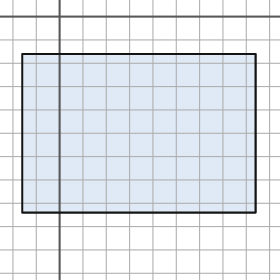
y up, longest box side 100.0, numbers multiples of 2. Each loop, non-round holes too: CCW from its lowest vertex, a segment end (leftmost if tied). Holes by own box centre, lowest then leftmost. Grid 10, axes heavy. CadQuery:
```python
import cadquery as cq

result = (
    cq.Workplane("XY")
    .moveTo(-16.0, -84.0)
    .lineTo(84.0, -84.0)
    .lineTo(84.0, -16.0)
    .lineTo(-16.0, -16.0)
    .close()
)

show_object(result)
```